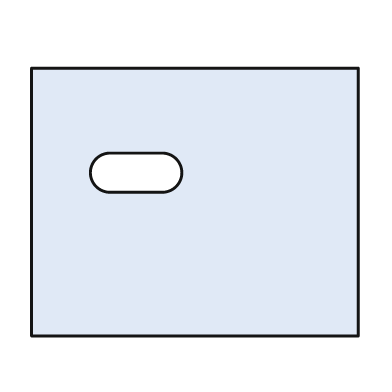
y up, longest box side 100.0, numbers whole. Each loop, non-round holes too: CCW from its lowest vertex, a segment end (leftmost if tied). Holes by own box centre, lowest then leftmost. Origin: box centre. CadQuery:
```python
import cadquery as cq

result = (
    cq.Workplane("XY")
    .moveTo(-50.0, -41.0)
    .lineTo(50.0, -41.0)
    .lineTo(50.0, 41.0)
    .lineTo(-50.0, 41.0)
    .close()
    .moveTo(-26.0, 3.0)
    .lineTo(-10.0, 3.0)
    .threePointArc((-4.0, 9.0), (-10.0, 15.0))
    .lineTo(-26.0, 15.0)
    .threePointArc((-32.0, 9.0), (-26.0, 3.0))
    .close()
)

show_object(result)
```